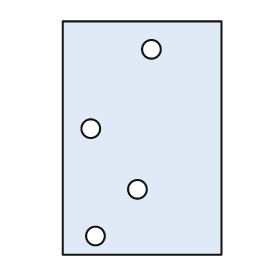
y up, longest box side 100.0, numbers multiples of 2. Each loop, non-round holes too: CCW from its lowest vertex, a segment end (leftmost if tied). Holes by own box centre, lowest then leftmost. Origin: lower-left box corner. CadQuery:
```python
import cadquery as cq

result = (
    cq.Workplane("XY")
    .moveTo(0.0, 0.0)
    .lineTo(68.0, 0.0)
    .lineTo(68.0, 100.0)
    .lineTo(0.0, 100.0)
    .close()
    .moveTo(14.0, 8.0)
    .circle(4.0)
    .moveTo(32.0, 28.0)
    .circle(4.0)
    .moveTo(12.0, 54.0)
    .circle(4.0)
    .moveTo(38.0, 88.0)
    .circle(4.0)
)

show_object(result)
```